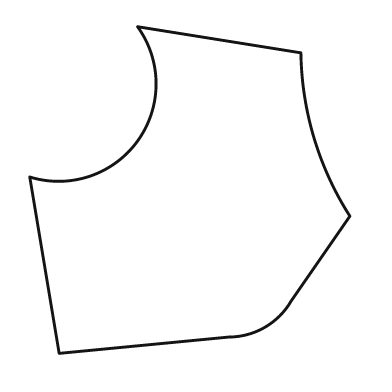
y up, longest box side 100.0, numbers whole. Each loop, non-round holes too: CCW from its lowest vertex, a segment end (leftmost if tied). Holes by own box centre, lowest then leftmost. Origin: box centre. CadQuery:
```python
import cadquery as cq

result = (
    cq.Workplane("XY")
    .moveTo(-40.0, -50.0)
    .lineTo(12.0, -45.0)
    .threePointArc((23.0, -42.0), (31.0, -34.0))
    .lineTo(49.0, -8.0)
    .threePointArc((38.0, 16.0), (34.0, 42.0))
    .lineTo(-16.0, 50.0)
    .threePointArc((-16.0, 15.0), (-49.0, 4.0))
    .close()
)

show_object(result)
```